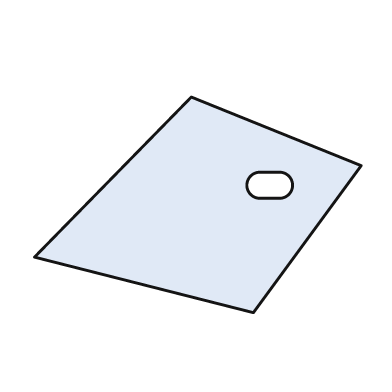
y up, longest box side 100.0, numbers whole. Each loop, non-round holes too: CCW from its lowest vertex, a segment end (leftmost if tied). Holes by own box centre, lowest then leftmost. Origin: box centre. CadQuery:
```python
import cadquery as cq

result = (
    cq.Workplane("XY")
    .moveTo(17.0, -33.0)
    .lineTo(50.0, 12.0)
    .lineTo(-2.0, 33.0)
    .lineTo(-50.0, -16.0)
    .close()
    .moveTo(19.0, 2.0)
    .lineTo(25.0, 2.0)
    .threePointArc((29.0, 6.0), (25.0, 10.0))
    .lineTo(19.0, 10.0)
    .threePointArc((15.0, 6.0), (19.0, 2.0))
    .close()
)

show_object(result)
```